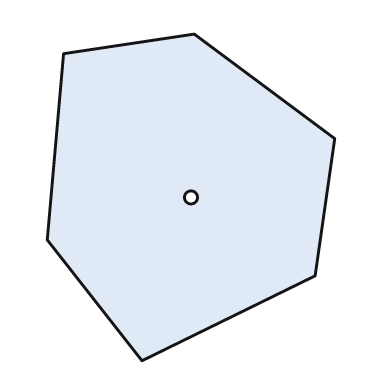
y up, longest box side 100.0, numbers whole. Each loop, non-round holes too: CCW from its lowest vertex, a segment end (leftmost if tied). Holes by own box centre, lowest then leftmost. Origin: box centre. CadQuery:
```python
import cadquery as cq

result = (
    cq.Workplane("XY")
    .moveTo(-15.0, -50.0)
    .lineTo(38.0, -24.0)
    .lineTo(44.0, 18.0)
    .lineTo(1.0, 50.0)
    .lineTo(-39.0, 44.0)
    .lineTo(-44.0, -13.0)
    .close()
    .moveTo(0.0, 0.0)
    .circle(2.0)
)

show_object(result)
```